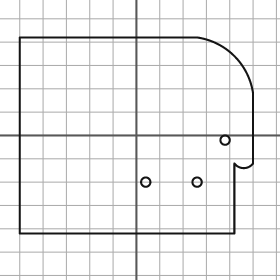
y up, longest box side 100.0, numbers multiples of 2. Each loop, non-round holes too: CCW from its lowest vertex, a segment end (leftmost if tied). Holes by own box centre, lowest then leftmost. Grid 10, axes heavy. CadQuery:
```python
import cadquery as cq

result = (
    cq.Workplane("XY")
    .moveTo(-50.0, -42.0)
    .lineTo(42.0, -42.0)
    .lineTo(42.0, -12.0)
    .threePointArc((46.0, -14.0), (50.0, -12.0))
    .lineTo(50.0, 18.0)
    .threePointArc((42.0, 34.0), (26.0, 42.0))
    .lineTo(-50.0, 42.0)
    .close()
    .moveTo(4.0, -20.0)
    .circle(2.0)
    .moveTo(26.0, -20.0)
    .circle(2.0)
    .moveTo(38.0, -2.0)
    .circle(2.0)
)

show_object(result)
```